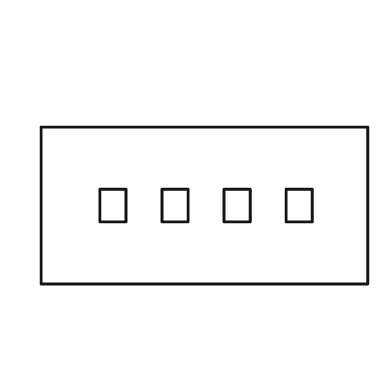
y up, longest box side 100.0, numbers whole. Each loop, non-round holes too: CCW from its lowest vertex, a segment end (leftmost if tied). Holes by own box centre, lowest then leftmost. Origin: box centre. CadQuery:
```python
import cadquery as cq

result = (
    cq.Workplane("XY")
    .moveTo(-50.0, -24.0)
    .lineTo(50.0, -24.0)
    .lineTo(50.0, 24.0)
    .lineTo(-50.0, 24.0)
    .close()
    .moveTo(-32.0, -5.0)
    .lineTo(-24.0, -5.0)
    .lineTo(-24.0, 5.0)
    .lineTo(-32.0, 5.0)
    .close()
    .moveTo(-13.0, -5.0)
    .lineTo(-5.0, -5.0)
    .lineTo(-5.0, 5.0)
    .lineTo(-13.0, 5.0)
    .close()
    .moveTo(6.0, -5.0)
    .lineTo(14.0, -5.0)
    .lineTo(14.0, 5.0)
    .lineTo(6.0, 5.0)
    .close()
    .moveTo(25.0, -5.0)
    .lineTo(33.0, -5.0)
    .lineTo(33.0, 5.0)
    .lineTo(25.0, 5.0)
    .close()
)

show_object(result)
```